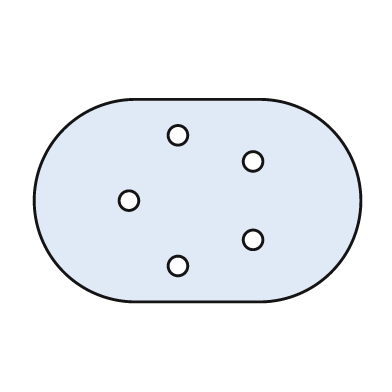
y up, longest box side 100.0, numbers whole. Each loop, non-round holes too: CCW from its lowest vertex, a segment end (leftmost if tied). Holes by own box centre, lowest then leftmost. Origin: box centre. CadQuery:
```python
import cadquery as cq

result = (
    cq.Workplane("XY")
    .moveTo(-19.0, -31.0)
    .lineTo(19.0, -31.0)
    .threePointArc((50.0, 0.0), (19.0, 31.0))
    .lineTo(-19.0, 31.0)
    .threePointArc((-50.0, 0.0), (-19.0, -31.0))
    .close()
    .moveTo(-6.0, -20.0)
    .circle(3.0)
    .moveTo(17.0, -12.0)
    .circle(3.0)
    .moveTo(-21.0, 0.0)
    .circle(3.0)
    .moveTo(17.0, 12.0)
    .circle(3.0)
    .moveTo(-6.0, 20.0)
    .circle(3.0)
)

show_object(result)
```